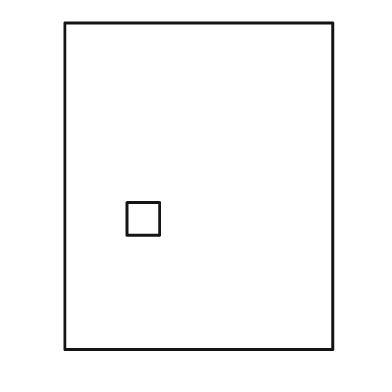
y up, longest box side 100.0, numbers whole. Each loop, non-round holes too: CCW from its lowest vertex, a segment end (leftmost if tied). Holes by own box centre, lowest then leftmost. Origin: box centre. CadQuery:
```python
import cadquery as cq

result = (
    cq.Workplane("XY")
    .moveTo(-41.0, -50.0)
    .lineTo(41.0, -50.0)
    .lineTo(41.0, 50.0)
    .lineTo(-41.0, 50.0)
    .close()
    .moveTo(-22.0, -15.0)
    .lineTo(-12.0, -15.0)
    .lineTo(-12.0, -5.0)
    .lineTo(-22.0, -5.0)
    .close()
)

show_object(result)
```